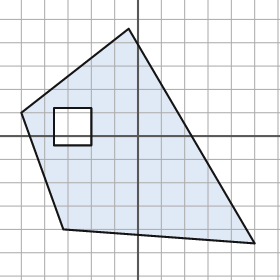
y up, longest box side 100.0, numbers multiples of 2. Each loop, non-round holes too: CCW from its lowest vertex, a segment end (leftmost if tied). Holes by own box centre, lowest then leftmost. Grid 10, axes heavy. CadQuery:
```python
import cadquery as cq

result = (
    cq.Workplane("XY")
    .moveTo(50.0, -46.0)
    .lineTo(-4.0, 46.0)
    .lineTo(-50.0, 10.0)
    .lineTo(-32.0, -40.0)
    .close()
    .moveTo(-36.0, -4.0)
    .lineTo(-20.0, -4.0)
    .lineTo(-20.0, 12.0)
    .lineTo(-36.0, 12.0)
    .close()
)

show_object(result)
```